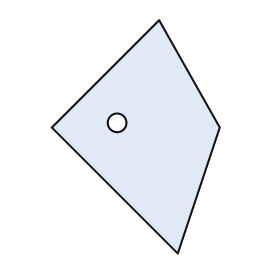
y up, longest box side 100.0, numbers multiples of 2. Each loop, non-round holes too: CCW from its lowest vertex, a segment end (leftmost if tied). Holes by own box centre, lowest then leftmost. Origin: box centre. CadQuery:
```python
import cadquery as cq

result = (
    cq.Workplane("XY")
    .moveTo(18.0, -50.0)
    .lineTo(36.0, 4.0)
    .lineTo(10.0, 50.0)
    .lineTo(-36.0, 4.0)
    .close()
    .moveTo(-8.0, 6.0)
    .circle(4.0)
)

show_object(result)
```